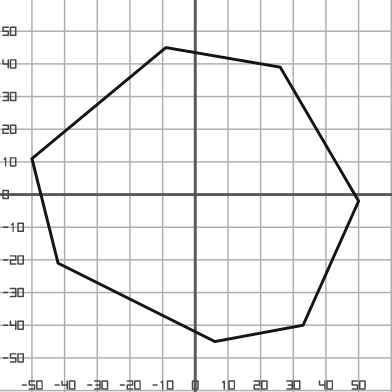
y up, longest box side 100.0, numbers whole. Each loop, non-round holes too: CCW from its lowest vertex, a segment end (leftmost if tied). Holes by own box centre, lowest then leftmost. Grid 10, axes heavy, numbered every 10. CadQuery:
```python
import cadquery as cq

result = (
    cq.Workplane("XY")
    .moveTo(6.0, -45.0)
    .lineTo(33.0, -40.0)
    .lineTo(50.0, -2.0)
    .lineTo(26.0, 39.0)
    .lineTo(-9.0, 45.0)
    .lineTo(-50.0, 11.0)
    .lineTo(-42.0, -21.0)
    .close()
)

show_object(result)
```